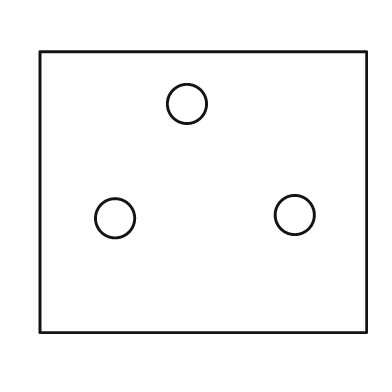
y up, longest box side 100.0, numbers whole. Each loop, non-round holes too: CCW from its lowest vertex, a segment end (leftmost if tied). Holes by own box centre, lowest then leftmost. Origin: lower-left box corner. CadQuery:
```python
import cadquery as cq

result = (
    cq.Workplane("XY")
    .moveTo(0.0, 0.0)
    .lineTo(100.0, 0.0)
    .lineTo(100.0, 86.0)
    .lineTo(0.0, 86.0)
    .close()
    .moveTo(23.0, 35.0)
    .circle(6.0)
    .moveTo(78.0, 36.0)
    .circle(6.0)
    .moveTo(45.0, 70.0)
    .circle(6.0)
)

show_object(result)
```